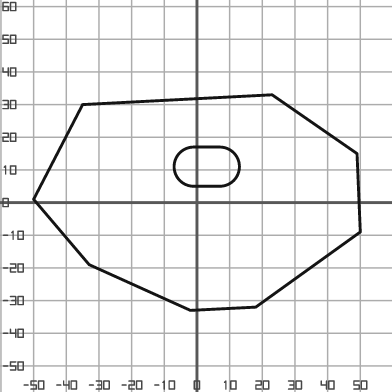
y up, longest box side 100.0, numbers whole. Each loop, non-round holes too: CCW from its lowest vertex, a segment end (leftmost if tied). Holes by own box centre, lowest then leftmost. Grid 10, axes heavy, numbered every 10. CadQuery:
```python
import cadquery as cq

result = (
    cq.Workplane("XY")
    .moveTo(-2.0, -33.0)
    .lineTo(18.0, -32.0)
    .lineTo(50.0, -9.0)
    .lineTo(49.0, 15.0)
    .lineTo(23.0, 33.0)
    .lineTo(-35.0, 30.0)
    .lineTo(-50.0, 1.0)
    .lineTo(-33.0, -19.0)
    .close()
    .moveTo(-1.0, 5.0)
    .lineTo(7.0, 5.0)
    .threePointArc((13.0, 11.0), (7.0, 17.0))
    .lineTo(-1.0, 17.0)
    .threePointArc((-7.0, 11.0), (-1.0, 5.0))
    .close()
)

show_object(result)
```